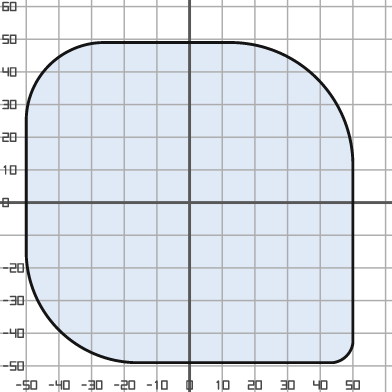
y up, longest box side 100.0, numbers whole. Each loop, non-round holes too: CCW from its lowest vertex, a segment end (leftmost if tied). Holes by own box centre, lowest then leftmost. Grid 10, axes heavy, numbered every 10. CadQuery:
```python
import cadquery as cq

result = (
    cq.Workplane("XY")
    .moveTo(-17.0, -49.0)
    .lineTo(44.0, -49.0)
    .threePointArc((48.0, -47.0), (50.0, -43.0))
    .lineTo(50.0, 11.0)
    .threePointArc((39.0, 38.0), (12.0, 49.0))
    .lineTo(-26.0, 49.0)
    .threePointArc((-43.0, 42.0), (-50.0, 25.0))
    .lineTo(-50.0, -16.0)
    .threePointArc((-40.0, -39.0), (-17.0, -49.0))
    .close()
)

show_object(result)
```